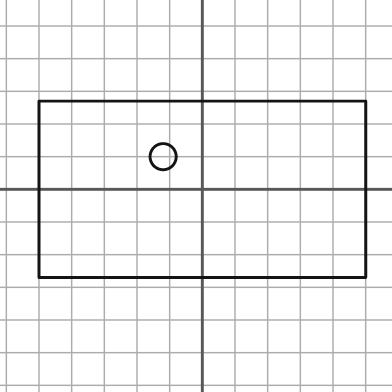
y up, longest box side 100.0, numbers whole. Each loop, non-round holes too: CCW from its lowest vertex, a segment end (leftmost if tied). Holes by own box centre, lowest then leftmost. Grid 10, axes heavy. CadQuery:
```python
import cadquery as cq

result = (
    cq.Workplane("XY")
    .moveTo(-50.0, -27.0)
    .lineTo(50.0, -27.0)
    .lineTo(50.0, 27.0)
    .lineTo(-50.0, 27.0)
    .close()
    .moveTo(-12.0, 10.0)
    .circle(4.0)
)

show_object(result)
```